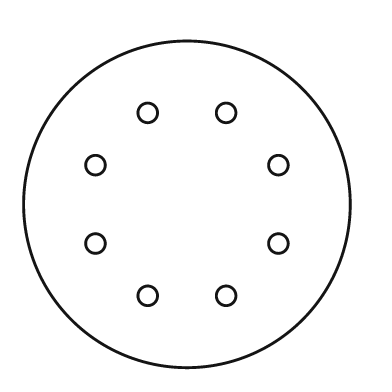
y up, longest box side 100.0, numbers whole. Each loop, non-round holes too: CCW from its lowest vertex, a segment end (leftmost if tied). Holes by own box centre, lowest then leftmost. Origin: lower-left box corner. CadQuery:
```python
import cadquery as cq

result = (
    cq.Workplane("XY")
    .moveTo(50.0, 50.0)
    .circle(50.0)
    .moveTo(38.0, 22.0)
    .circle(3.0)
    .moveTo(62.0, 22.0)
    .circle(3.0)
    .moveTo(22.0, 38.0)
    .circle(3.0)
    .moveTo(78.0, 38.0)
    .circle(3.0)
    .moveTo(22.0, 62.0)
    .circle(3.0)
    .moveTo(78.0, 62.0)
    .circle(3.0)
    .moveTo(38.0, 78.0)
    .circle(3.0)
    .moveTo(62.0, 78.0)
    .circle(3.0)
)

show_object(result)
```